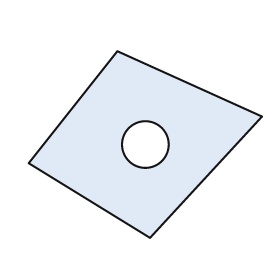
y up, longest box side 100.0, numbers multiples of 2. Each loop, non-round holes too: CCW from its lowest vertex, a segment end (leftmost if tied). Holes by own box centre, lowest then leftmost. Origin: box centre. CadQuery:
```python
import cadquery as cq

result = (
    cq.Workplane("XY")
    .moveTo(2.0, -40.0)
    .lineTo(50.0, 12.0)
    .lineTo(-12.0, 40.0)
    .lineTo(-50.0, -8.0)
    .close()
    .moveTo(0.0, 0.0)
    .circle(10.0)
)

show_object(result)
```